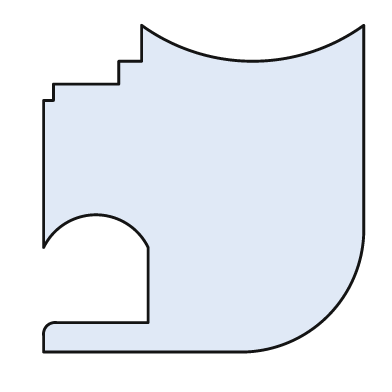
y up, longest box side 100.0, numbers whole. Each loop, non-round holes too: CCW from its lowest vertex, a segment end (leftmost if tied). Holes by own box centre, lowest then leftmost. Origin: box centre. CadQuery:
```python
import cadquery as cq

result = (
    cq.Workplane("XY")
    .moveTo(-49.0, -50.0)
    .lineTo(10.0, -50.0)
    .threePointArc((38.0, -39.0), (49.0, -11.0))
    .lineTo(49.0, 50.0)
    .threePointArc((15.0, 39.0), (-19.0, 50.0))
    .lineTo(-19.0, 39.0)
    .lineTo(-26.0, 39.0)
    .lineTo(-26.0, 32.0)
    .lineTo(-46.0, 32.0)
    .lineTo(-46.0, 27.0)
    .lineTo(-49.0, 27.0)
    .lineTo(-49.0, -18.0)
    .threePointArc((-33.0, -8.0), (-17.0, -18.0))
    .lineTo(-17.0, -41.0)
    .lineTo(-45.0, -41.0)
    .threePointArc((-48.0, -42.0), (-49.0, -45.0))
    .close()
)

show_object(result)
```